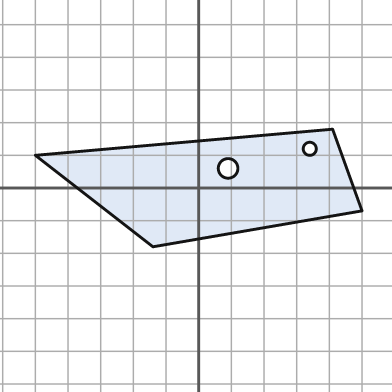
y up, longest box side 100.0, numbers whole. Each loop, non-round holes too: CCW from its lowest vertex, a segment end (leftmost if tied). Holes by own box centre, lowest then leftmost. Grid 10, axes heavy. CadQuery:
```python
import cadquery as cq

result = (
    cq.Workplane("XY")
    .moveTo(-14.0, -18.0)
    .lineTo(50.0, -7.0)
    .lineTo(41.0, 18.0)
    .lineTo(-50.0, 10.0)
    .close()
    .moveTo(9.0, 6.0)
    .circle(3.0)
    .moveTo(34.0, 12.0)
    .circle(2.0)
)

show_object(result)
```